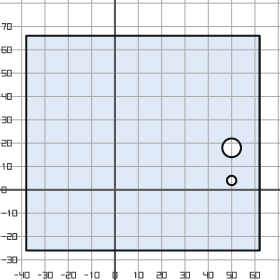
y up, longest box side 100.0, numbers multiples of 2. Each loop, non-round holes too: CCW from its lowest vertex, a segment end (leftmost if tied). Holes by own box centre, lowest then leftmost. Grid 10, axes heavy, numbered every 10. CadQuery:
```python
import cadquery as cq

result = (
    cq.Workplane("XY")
    .moveTo(-38.0, -26.0)
    .lineTo(62.0, -26.0)
    .lineTo(62.0, 66.0)
    .lineTo(-38.0, 66.0)
    .close()
    .moveTo(50.0, 4.0)
    .circle(2.0)
    .moveTo(50.0, 18.0)
    .circle(4.0)
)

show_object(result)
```